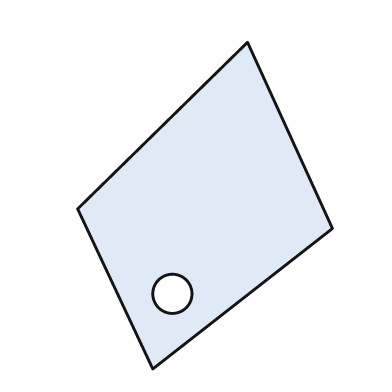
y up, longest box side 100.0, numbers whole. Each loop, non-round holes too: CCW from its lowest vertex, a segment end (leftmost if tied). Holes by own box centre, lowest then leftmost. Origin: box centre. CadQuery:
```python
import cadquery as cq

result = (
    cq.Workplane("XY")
    .moveTo(-16.0, -50.0)
    .lineTo(39.0, -7.0)
    .lineTo(13.0, 50.0)
    .lineTo(-39.0, -1.0)
    .close()
    .moveTo(-10.0, -27.0)
    .circle(6.0)
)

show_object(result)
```